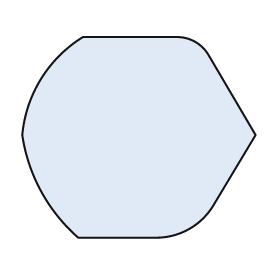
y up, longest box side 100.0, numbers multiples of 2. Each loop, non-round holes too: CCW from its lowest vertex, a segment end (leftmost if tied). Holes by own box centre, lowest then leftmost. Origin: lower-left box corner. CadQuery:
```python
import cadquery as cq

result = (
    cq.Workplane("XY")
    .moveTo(24.0, 0.0)
    .lineTo(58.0, 0.0)
    .threePointArc((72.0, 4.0), (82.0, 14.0))
    .lineTo(100.0, 44.0)
    .lineTo(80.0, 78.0)
    .threePointArc((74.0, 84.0), (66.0, 86.0))
    .lineTo(26.0, 86.0)
    .threePointArc((8.0, 68.0), (0.0, 44.0))
    .threePointArc((8.0, 20.0), (24.0, 0.0))
    .close()
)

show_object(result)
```